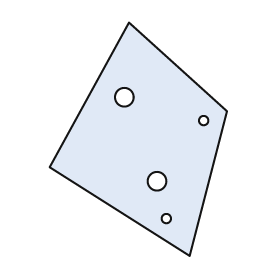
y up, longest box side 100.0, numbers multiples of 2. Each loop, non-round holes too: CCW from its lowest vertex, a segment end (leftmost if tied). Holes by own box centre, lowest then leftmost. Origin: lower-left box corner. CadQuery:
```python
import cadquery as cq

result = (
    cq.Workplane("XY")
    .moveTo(60.0, 0.0)
    .lineTo(76.0, 62.0)
    .lineTo(34.0, 100.0)
    .lineTo(0.0, 38.0)
    .close()
    .moveTo(50.0, 16.0)
    .circle(2.0)
    .moveTo(46.0, 32.0)
    .circle(4.0)
    .moveTo(66.0, 58.0)
    .circle(2.0)
    .moveTo(32.0, 68.0)
    .circle(4.0)
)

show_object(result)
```